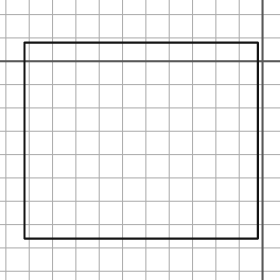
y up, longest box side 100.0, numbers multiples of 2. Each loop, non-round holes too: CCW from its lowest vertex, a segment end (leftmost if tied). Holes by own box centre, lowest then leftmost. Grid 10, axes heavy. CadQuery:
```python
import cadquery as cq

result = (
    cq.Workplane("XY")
    .moveTo(-102.0, -76.0)
    .lineTo(-2.0, -76.0)
    .lineTo(-2.0, 8.0)
    .lineTo(-102.0, 8.0)
    .close()
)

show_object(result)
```